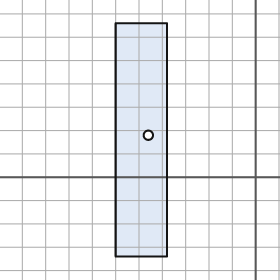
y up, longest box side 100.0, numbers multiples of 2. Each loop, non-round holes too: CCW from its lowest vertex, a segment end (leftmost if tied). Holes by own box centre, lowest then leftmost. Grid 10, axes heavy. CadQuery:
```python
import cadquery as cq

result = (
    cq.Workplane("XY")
    .moveTo(-60.0, -34.0)
    .lineTo(-38.0, -34.0)
    .lineTo(-38.0, 66.0)
    .lineTo(-60.0, 66.0)
    .close()
    .moveTo(-46.0, 18.0)
    .circle(2.0)
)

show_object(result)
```